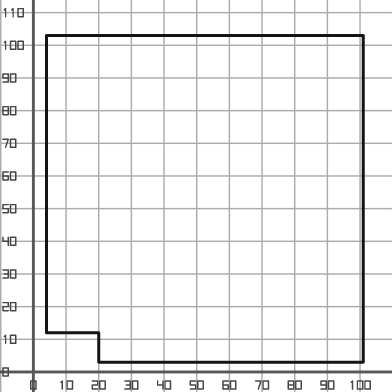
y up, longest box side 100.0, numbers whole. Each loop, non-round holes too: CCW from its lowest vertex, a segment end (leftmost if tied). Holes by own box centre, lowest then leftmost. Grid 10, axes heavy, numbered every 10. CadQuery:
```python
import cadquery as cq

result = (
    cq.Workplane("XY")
    .moveTo(20.0, 3.0)
    .lineTo(101.0, 3.0)
    .lineTo(101.0, 103.0)
    .lineTo(4.0, 103.0)
    .lineTo(4.0, 12.0)
    .lineTo(20.0, 12.0)
    .close()
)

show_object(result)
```